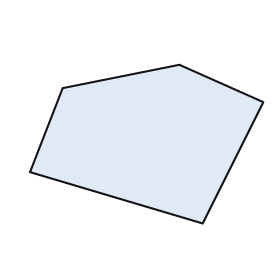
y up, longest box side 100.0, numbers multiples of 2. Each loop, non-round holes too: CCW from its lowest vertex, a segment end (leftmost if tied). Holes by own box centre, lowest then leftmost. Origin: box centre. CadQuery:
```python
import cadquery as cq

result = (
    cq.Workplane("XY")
    .moveTo(24.0, -34.0)
    .lineTo(50.0, 18.0)
    .lineTo(14.0, 34.0)
    .lineTo(-36.0, 24.0)
    .lineTo(-50.0, -12.0)
    .close()
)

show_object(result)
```